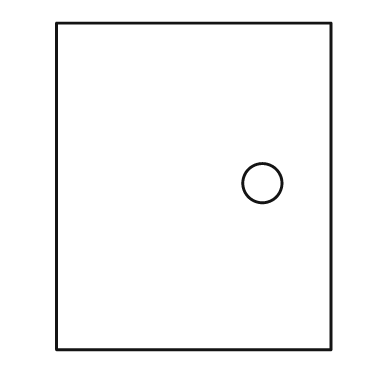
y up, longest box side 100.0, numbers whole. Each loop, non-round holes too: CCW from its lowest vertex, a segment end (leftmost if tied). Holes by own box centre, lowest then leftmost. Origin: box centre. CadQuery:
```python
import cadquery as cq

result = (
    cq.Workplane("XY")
    .moveTo(-42.0, -50.0)
    .lineTo(42.0, -50.0)
    .lineTo(42.0, 50.0)
    .lineTo(-42.0, 50.0)
    .close()
    .moveTo(21.0, 1.0)
    .circle(6.0)
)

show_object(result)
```